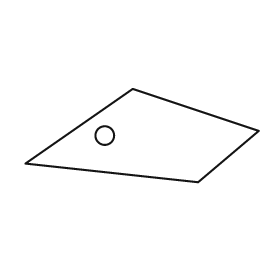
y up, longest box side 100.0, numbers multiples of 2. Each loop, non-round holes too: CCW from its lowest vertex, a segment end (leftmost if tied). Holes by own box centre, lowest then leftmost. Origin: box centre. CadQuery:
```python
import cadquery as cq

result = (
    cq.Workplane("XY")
    .moveTo(24.0, -20.0)
    .lineTo(50.0, 2.0)
    .lineTo(-4.0, 20.0)
    .lineTo(-50.0, -12.0)
    .close()
    .moveTo(-16.0, 0.0)
    .circle(4.0)
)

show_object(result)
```